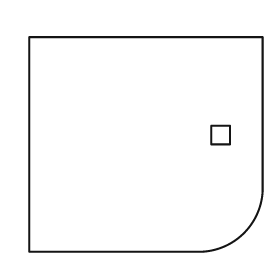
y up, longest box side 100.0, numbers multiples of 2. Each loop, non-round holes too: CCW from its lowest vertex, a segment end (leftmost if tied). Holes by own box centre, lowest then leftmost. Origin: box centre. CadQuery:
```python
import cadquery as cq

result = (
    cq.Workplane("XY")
    .moveTo(-50.0, -46.0)
    .lineTo(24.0, -46.0)
    .threePointArc((42.0, -38.0), (50.0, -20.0))
    .lineTo(50.0, 46.0)
    .lineTo(-50.0, 46.0)
    .close()
    .moveTo(28.0, 0.0)
    .lineTo(36.0, 0.0)
    .lineTo(36.0, 8.0)
    .lineTo(28.0, 8.0)
    .close()
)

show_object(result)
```